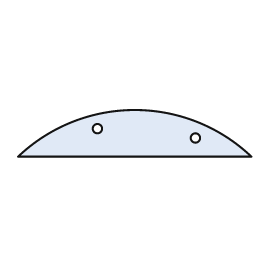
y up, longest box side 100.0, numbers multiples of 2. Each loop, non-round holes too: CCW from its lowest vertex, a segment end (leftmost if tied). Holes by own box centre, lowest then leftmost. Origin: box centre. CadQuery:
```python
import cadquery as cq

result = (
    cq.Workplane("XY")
    .moveTo(-50.0, -10.0)
    .lineTo(50.0, -10.0)
    .threePointArc((0.0, 10.0), (-50.0, -10.0))
    .close()
    .moveTo(26.0, -2.0)
    .circle(2.0)
    .moveTo(-16.0, 2.0)
    .circle(2.0)
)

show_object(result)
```